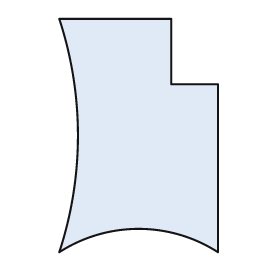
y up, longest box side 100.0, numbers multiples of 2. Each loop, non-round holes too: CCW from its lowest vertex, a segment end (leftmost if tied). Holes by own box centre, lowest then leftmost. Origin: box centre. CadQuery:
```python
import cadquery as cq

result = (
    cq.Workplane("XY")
    .moveTo(-34.0, -50.0)
    .threePointArc((0.0, -40.0), (34.0, -50.0))
    .lineTo(34.0, 22.0)
    .lineTo(14.0, 22.0)
    .lineTo(14.0, 50.0)
    .lineTo(-34.0, 50.0)
    .threePointArc((-26.0, 0.0), (-34.0, -50.0))
    .close()
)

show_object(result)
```